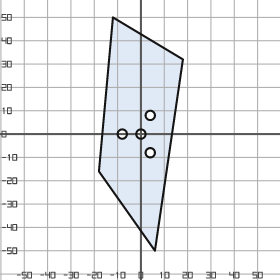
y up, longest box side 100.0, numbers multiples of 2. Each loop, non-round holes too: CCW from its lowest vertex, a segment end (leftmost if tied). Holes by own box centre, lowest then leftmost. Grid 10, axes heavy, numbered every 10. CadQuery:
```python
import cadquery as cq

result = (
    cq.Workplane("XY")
    .moveTo(6.0, -50.0)
    .lineTo(18.0, 32.0)
    .lineTo(-12.0, 50.0)
    .lineTo(-18.0, -16.0)
    .close()
    .moveTo(4.0, -8.0)
    .circle(2.0)
    .moveTo(-8.0, 0.0)
    .circle(2.0)
    .moveTo(0.0, 0.0)
    .circle(2.0)
    .moveTo(4.0, 8.0)
    .circle(2.0)
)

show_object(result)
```